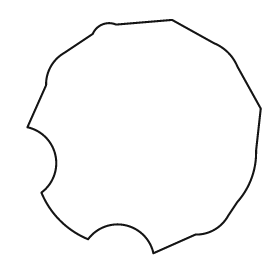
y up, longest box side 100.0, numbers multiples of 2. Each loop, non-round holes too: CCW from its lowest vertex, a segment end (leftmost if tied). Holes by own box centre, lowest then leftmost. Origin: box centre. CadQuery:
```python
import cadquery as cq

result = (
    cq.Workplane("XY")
    .moveTo(4.0, -50.0)
    .lineTo(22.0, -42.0)
    .threePointArc((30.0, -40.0), (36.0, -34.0))
    .lineTo(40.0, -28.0)
    .threePointArc((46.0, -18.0), (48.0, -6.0))
    .lineTo(50.0, 12.0)
    .lineTo(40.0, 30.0)
    .threePointArc((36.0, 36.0), (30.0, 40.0))
    .lineTo(12.0, 50.0)
    .lineTo(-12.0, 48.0)
    .threePointArc((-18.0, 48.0), (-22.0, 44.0))
    .lineTo(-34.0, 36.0)
    .threePointArc((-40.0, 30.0), (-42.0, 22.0))
    .lineTo(-50.0, 4.0)
    .threePointArc((-38.0, -8.0), (-44.0, -24.0))
    .threePointArc((-36.0, -36.0), (-24.0, -44.0))
    .threePointArc((-8.0, -38.0), (4.0, -50.0))
    .close()
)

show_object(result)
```